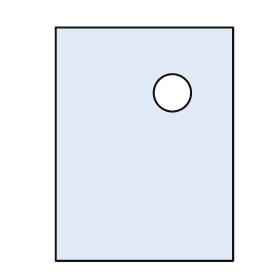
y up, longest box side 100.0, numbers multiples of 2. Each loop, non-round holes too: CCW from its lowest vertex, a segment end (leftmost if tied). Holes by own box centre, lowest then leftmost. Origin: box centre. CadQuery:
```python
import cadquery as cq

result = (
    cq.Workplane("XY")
    .moveTo(-38.0, -50.0)
    .lineTo(38.0, -50.0)
    .lineTo(38.0, 50.0)
    .lineTo(-38.0, 50.0)
    .close()
    .moveTo(12.0, 22.0)
    .circle(8.0)
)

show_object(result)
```